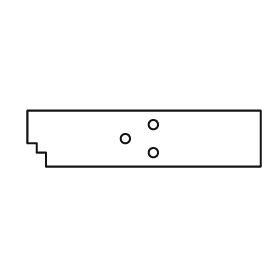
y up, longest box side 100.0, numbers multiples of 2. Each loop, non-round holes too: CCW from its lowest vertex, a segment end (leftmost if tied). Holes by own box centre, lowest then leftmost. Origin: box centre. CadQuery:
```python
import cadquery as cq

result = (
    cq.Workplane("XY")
    .moveTo(-42.0, -12.0)
    .lineTo(50.0, -12.0)
    .lineTo(50.0, 12.0)
    .lineTo(-50.0, 12.0)
    .lineTo(-50.0, -2.0)
    .lineTo(-46.0, -2.0)
    .lineTo(-46.0, -6.0)
    .lineTo(-42.0, -6.0)
    .close()
    .moveTo(4.0, -6.0)
    .circle(2.0)
    .moveTo(-8.0, 0.0)
    .circle(2.0)
    .moveTo(4.0, 6.0)
    .circle(2.0)
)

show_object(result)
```